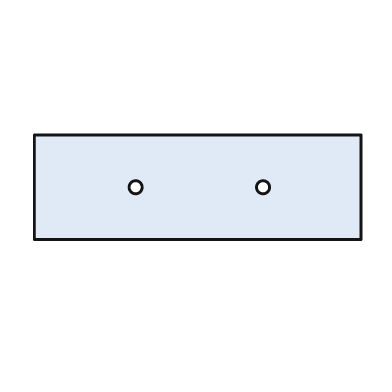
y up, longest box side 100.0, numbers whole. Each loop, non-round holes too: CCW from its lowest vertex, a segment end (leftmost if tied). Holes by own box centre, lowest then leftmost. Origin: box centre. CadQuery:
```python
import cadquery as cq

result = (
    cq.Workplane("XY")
    .moveTo(-50.0, -16.0)
    .lineTo(50.0, -16.0)
    .lineTo(50.0, 16.0)
    .lineTo(-50.0, 16.0)
    .close()
    .moveTo(-19.0, 0.0)
    .circle(2.0)
    .moveTo(20.0, 0.0)
    .circle(2.0)
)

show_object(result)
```